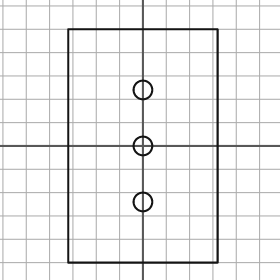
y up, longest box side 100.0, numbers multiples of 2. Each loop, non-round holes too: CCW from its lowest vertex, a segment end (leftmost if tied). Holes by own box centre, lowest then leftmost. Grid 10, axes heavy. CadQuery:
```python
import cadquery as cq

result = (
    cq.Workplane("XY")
    .moveTo(-32.0, -50.0)
    .lineTo(32.0, -50.0)
    .lineTo(32.0, 50.0)
    .lineTo(-32.0, 50.0)
    .close()
    .moveTo(0.0, -24.0)
    .circle(4.0)
    .moveTo(0.0, 0.0)
    .circle(4.0)
    .moveTo(0.0, 24.0)
    .circle(4.0)
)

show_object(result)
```